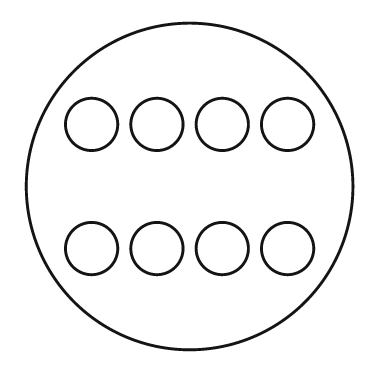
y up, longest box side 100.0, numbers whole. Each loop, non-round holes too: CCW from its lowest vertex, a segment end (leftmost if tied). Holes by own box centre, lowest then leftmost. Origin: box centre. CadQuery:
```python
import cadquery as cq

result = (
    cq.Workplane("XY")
    .moveTo(0.0, 0.0)
    .circle(50.0)
    .moveTo(-30.0, -19.0)
    .circle(8.0)
    .moveTo(-10.0, -19.0)
    .circle(8.0)
    .moveTo(10.0, -19.0)
    .circle(8.0)
    .moveTo(30.0, -19.0)
    .circle(8.0)
    .moveTo(-30.0, 19.0)
    .circle(8.0)
    .moveTo(-10.0, 19.0)
    .circle(8.0)
    .moveTo(10.0, 19.0)
    .circle(8.0)
    .moveTo(30.0, 19.0)
    .circle(8.0)
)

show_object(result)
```